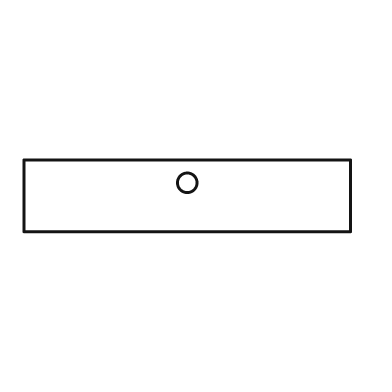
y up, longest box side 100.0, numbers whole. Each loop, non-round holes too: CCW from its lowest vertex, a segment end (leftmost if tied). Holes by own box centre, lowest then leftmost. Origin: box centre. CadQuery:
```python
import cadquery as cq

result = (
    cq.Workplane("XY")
    .moveTo(-50.0, -11.0)
    .lineTo(50.0, -11.0)
    .lineTo(50.0, 11.0)
    .lineTo(-50.0, 11.0)
    .close()
    .moveTo(0.0, 4.0)
    .circle(3.0)
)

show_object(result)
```